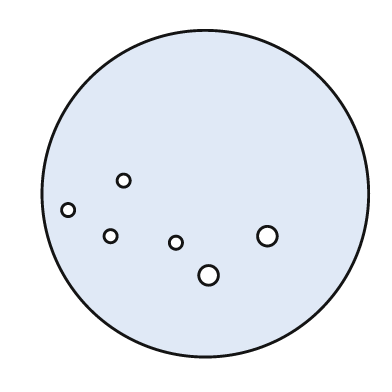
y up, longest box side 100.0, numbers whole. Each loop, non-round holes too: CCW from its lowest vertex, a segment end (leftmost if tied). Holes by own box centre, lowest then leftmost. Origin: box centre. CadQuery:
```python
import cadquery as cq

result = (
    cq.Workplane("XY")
    .moveTo(0.0, 0.0)
    .circle(50.0)
    .moveTo(1.0, -25.0)
    .circle(3.0)
    .moveTo(-9.0, -15.0)
    .circle(2.0)
    .moveTo(-29.0, -13.0)
    .circle(2.0)
    .moveTo(19.0, -13.0)
    .circle(3.0)
    .moveTo(-42.0, -5.0)
    .circle(2.0)
    .moveTo(-25.0, 4.0)
    .circle(2.0)
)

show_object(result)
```